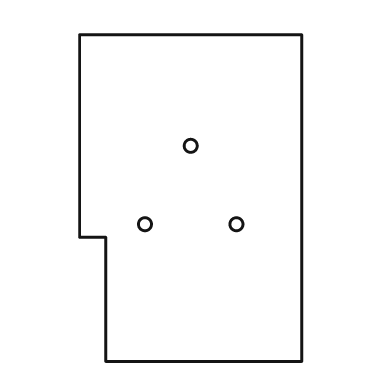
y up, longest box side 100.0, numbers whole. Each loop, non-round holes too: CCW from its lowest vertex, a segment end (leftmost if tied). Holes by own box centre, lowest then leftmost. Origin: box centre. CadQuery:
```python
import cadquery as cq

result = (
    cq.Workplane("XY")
    .moveTo(-26.0, -50.0)
    .lineTo(34.0, -50.0)
    .lineTo(34.0, 50.0)
    .lineTo(-34.0, 50.0)
    .lineTo(-34.0, -12.0)
    .lineTo(-26.0, -12.0)
    .close()
    .moveTo(-14.0, -8.0)
    .circle(2.0)
    .moveTo(14.0, -8.0)
    .circle(2.0)
    .moveTo(0.0, 16.0)
    .circle(2.0)
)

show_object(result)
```